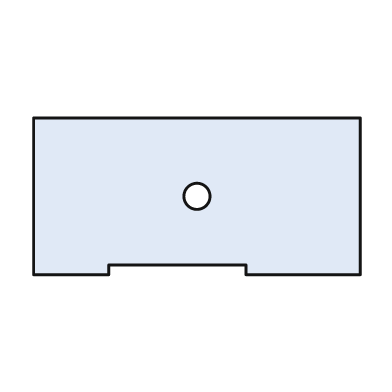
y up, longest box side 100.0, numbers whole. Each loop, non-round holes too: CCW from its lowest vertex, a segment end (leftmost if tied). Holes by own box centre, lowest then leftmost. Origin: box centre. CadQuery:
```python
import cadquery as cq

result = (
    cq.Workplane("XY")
    .moveTo(-50.0, -24.0)
    .lineTo(-27.0, -24.0)
    .lineTo(-27.0, -21.0)
    .lineTo(15.0, -21.0)
    .lineTo(15.0, -24.0)
    .lineTo(50.0, -24.0)
    .lineTo(50.0, 24.0)
    .lineTo(-50.0, 24.0)
    .close()
    .moveTo(0.0, 0.0)
    .circle(4.0)
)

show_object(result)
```